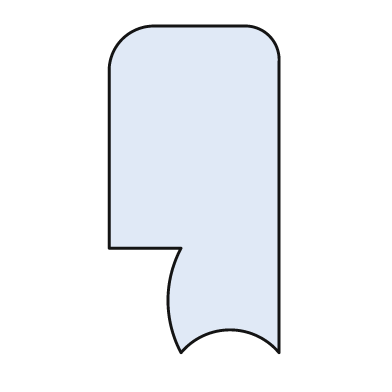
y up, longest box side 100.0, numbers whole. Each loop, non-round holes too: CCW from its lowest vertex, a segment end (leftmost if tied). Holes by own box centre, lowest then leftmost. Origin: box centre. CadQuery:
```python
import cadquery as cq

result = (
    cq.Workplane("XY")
    .moveTo(-4.0, -50.0)
    .threePointArc((11.0, -43.0), (26.0, -50.0))
    .lineTo(26.0, 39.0)
    .threePointArc((23.0, 47.0), (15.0, 50.0))
    .lineTo(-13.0, 50.0)
    .threePointArc((-22.0, 46.0), (-26.0, 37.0))
    .lineTo(-26.0, -18.0)
    .lineTo(-4.0, -18.0)
    .threePointArc((-8.0, -34.0), (-4.0, -50.0))
    .close()
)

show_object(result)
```